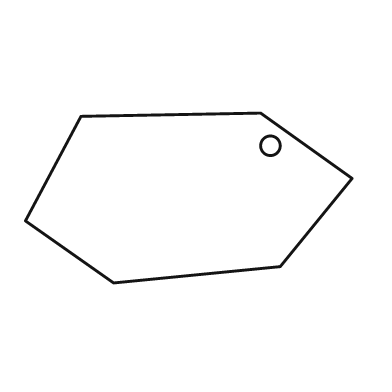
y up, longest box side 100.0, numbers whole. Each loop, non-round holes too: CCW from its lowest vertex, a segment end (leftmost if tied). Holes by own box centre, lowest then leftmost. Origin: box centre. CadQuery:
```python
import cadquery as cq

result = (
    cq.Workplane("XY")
    .moveTo(-23.0, -26.0)
    .lineTo(28.0, -21.0)
    .lineTo(50.0, 6.0)
    .lineTo(22.0, 26.0)
    .lineTo(-33.0, 25.0)
    .lineTo(-50.0, -7.0)
    .close()
    .moveTo(25.0, 16.0)
    .circle(3.0)
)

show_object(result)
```